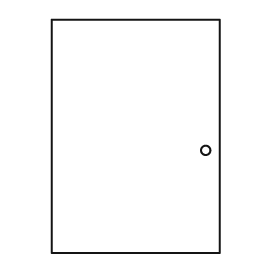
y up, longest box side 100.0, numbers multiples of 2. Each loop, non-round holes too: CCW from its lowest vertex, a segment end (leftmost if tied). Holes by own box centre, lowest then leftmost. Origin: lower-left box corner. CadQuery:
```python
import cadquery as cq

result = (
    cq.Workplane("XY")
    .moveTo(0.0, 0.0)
    .lineTo(72.0, 0.0)
    .lineTo(72.0, 100.0)
    .lineTo(0.0, 100.0)
    .close()
    .moveTo(66.0, 44.0)
    .circle(2.0)
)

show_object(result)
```